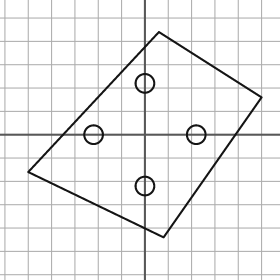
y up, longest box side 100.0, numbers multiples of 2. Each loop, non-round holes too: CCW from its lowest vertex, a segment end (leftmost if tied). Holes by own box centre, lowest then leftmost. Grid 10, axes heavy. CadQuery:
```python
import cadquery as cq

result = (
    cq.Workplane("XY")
    .moveTo(8.0, -44.0)
    .lineTo(50.0, 16.0)
    .lineTo(6.0, 44.0)
    .lineTo(-50.0, -16.0)
    .close()
    .moveTo(0.0, -22.0)
    .circle(4.0)
    .moveTo(-22.0, 0.0)
    .circle(4.0)
    .moveTo(22.0, 0.0)
    .circle(4.0)
    .moveTo(0.0, 22.0)
    .circle(4.0)
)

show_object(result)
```